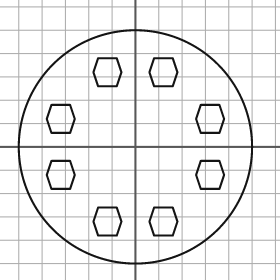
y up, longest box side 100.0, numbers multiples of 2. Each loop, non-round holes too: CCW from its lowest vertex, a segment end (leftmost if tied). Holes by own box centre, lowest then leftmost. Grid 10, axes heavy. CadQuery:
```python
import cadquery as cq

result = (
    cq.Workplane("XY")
    .moveTo(0.0, 0.0)
    .circle(50.0)
    .moveTo(-16.0, -38.0)
    .lineTo(-8.0, -38.0)
    .lineTo(-6.0, -32.0)
    .lineTo(-8.0, -26.0)
    .lineTo(-16.0, -26.0)
    .lineTo(-18.0, -32.0)
    .close()
    .moveTo(8.0, -38.0)
    .lineTo(16.0, -38.0)
    .lineTo(18.0, -32.0)
    .lineTo(16.0, -26.0)
    .lineTo(8.0, -26.0)
    .lineTo(6.0, -32.0)
    .close()
    .moveTo(-36.0, -18.0)
    .lineTo(-28.0, -18.0)
    .lineTo(-26.0, -12.0)
    .lineTo(-28.0, -6.0)
    .lineTo(-36.0, -6.0)
    .lineTo(-38.0, -12.0)
    .close()
    .moveTo(28.0, -18.0)
    .lineTo(36.0, -18.0)
    .lineTo(38.0, -12.0)
    .lineTo(36.0, -6.0)
    .lineTo(28.0, -6.0)
    .lineTo(26.0, -12.0)
    .close()
    .moveTo(-36.0, 6.0)
    .lineTo(-28.0, 6.0)
    .lineTo(-26.0, 12.0)
    .lineTo(-28.0, 18.0)
    .lineTo(-36.0, 18.0)
    .lineTo(-38.0, 12.0)
    .close()
    .moveTo(28.0, 6.0)
    .lineTo(36.0, 6.0)
    .lineTo(38.0, 12.0)
    .lineTo(36.0, 18.0)
    .lineTo(28.0, 18.0)
    .lineTo(26.0, 12.0)
    .close()
    .moveTo(-16.0, 26.0)
    .lineTo(-8.0, 26.0)
    .lineTo(-6.0, 32.0)
    .lineTo(-8.0, 38.0)
    .lineTo(-16.0, 38.0)
    .lineTo(-18.0, 32.0)
    .close()
    .moveTo(8.0, 26.0)
    .lineTo(16.0, 26.0)
    .lineTo(18.0, 32.0)
    .lineTo(16.0, 38.0)
    .lineTo(8.0, 38.0)
    .lineTo(6.0, 32.0)
    .close()
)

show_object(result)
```